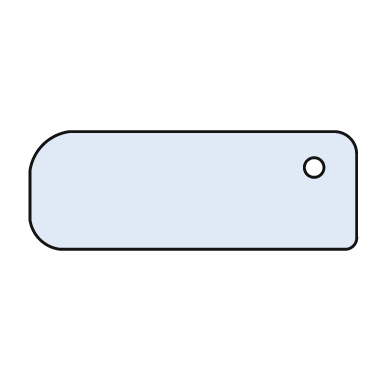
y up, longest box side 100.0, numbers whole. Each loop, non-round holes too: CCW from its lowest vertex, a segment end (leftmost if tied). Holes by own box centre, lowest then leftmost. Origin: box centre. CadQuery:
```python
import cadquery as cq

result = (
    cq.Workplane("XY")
    .moveTo(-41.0, -18.0)
    .lineTo(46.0, -18.0)
    .threePointArc((49.0, -17.0), (50.0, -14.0))
    .lineTo(50.0, 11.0)
    .threePointArc((48.0, 16.0), (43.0, 18.0))
    .lineTo(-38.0, 18.0)
    .threePointArc((-46.0, 14.0), (-50.0, 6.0))
    .lineTo(-50.0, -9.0)
    .threePointArc((-47.0, -15.0), (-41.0, -18.0))
    .close()
    .moveTo(37.0, 7.0)
    .circle(3.0)
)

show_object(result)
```